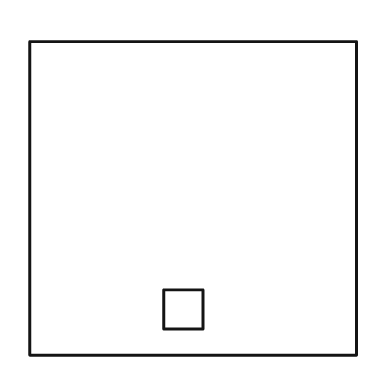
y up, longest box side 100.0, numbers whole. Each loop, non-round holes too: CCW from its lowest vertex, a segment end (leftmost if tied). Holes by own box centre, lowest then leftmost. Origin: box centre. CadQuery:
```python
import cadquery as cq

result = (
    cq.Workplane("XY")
    .moveTo(-50.0, -48.0)
    .lineTo(50.0, -48.0)
    .lineTo(50.0, 48.0)
    .lineTo(-50.0, 48.0)
    .close()
    .moveTo(-9.0, -40.0)
    .lineTo(3.0, -40.0)
    .lineTo(3.0, -28.0)
    .lineTo(-9.0, -28.0)
    .close()
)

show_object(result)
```